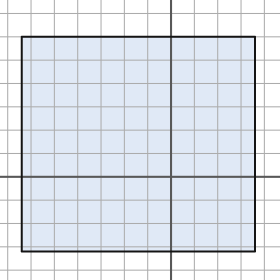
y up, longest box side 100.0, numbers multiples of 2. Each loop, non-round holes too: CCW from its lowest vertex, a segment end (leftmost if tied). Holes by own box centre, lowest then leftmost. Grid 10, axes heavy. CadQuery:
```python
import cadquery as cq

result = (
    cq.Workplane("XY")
    .moveTo(-64.0, -32.0)
    .lineTo(36.0, -32.0)
    .lineTo(36.0, 60.0)
    .lineTo(-64.0, 60.0)
    .close()
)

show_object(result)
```